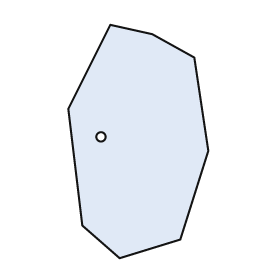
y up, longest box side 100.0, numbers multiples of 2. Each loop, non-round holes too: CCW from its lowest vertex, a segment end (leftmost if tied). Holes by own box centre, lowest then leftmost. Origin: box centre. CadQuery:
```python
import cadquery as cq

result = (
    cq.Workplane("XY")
    .moveTo(-8.0, -50.0)
    .lineTo(18.0, -42.0)
    .lineTo(30.0, -4.0)
    .lineTo(24.0, 36.0)
    .lineTo(6.0, 46.0)
    .lineTo(-12.0, 50.0)
    .lineTo(-30.0, 14.0)
    .lineTo(-24.0, -36.0)
    .close()
    .moveTo(-16.0, 2.0)
    .circle(2.0)
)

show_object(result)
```